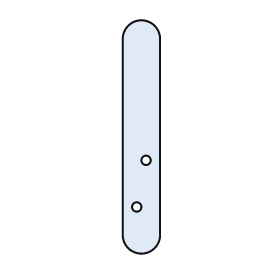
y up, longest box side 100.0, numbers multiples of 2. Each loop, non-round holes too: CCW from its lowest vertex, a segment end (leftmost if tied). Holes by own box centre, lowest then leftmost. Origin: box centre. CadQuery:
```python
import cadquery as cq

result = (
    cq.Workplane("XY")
    .moveTo(-8.0, -42.0)
    .threePointArc((0.0, -50.0), (8.0, -42.0))
    .lineTo(8.0, 42.0)
    .threePointArc((0.0, 50.0), (-8.0, 42.0))
    .close()
    .moveTo(-2.0, -30.0)
    .circle(2.0)
    .moveTo(2.0, -10.0)
    .circle(2.0)
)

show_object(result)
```